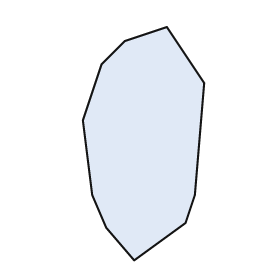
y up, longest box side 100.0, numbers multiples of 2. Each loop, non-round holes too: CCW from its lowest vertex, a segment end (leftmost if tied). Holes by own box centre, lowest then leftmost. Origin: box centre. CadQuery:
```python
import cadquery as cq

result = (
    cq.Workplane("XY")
    .moveTo(-4.0, -50.0)
    .lineTo(18.0, -34.0)
    .lineTo(22.0, -22.0)
    .lineTo(26.0, 26.0)
    .lineTo(10.0, 50.0)
    .lineTo(-8.0, 44.0)
    .lineTo(-18.0, 34.0)
    .lineTo(-26.0, 10.0)
    .lineTo(-22.0, -22.0)
    .lineTo(-16.0, -36.0)
    .close()
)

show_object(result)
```